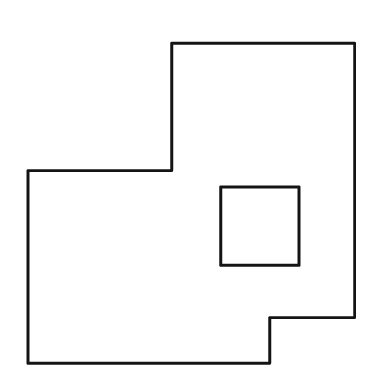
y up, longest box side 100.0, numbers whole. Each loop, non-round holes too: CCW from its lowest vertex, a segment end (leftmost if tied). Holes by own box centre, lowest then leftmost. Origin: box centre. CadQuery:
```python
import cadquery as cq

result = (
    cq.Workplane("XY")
    .moveTo(-50.0, -49.0)
    .lineTo(24.0, -49.0)
    .lineTo(24.0, -35.0)
    .lineTo(50.0, -35.0)
    .lineTo(50.0, 49.0)
    .lineTo(-6.0, 49.0)
    .lineTo(-6.0, 10.0)
    .lineTo(-50.0, 10.0)
    .close()
    .moveTo(9.0, -19.0)
    .lineTo(33.0, -19.0)
    .lineTo(33.0, 5.0)
    .lineTo(9.0, 5.0)
    .close()
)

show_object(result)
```